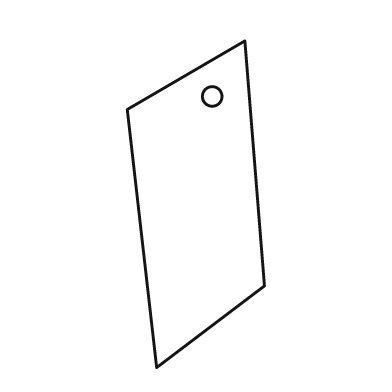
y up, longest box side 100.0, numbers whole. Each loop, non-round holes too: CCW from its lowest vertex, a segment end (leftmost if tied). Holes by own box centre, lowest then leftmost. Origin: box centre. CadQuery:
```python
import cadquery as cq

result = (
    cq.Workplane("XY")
    .moveTo(-12.0, -50.0)
    .lineTo(21.0, -25.0)
    .lineTo(15.0, 50.0)
    .lineTo(-21.0, 29.0)
    .close()
    .moveTo(5.0, 33.0)
    .circle(3.0)
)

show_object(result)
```